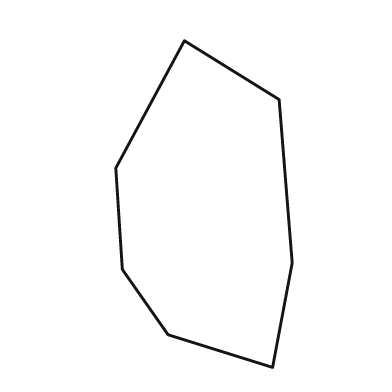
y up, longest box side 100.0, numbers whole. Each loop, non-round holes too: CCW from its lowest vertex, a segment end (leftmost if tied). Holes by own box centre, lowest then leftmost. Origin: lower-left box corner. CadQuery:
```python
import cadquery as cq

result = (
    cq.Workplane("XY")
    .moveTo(48.0, 0.0)
    .lineTo(54.0, 32.0)
    .lineTo(50.0, 82.0)
    .lineTo(21.0, 100.0)
    .lineTo(0.0, 61.0)
    .lineTo(2.0, 30.0)
    .lineTo(16.0, 10.0)
    .close()
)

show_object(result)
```